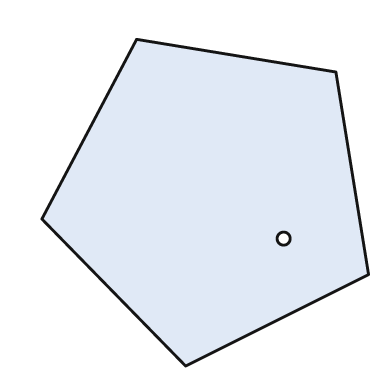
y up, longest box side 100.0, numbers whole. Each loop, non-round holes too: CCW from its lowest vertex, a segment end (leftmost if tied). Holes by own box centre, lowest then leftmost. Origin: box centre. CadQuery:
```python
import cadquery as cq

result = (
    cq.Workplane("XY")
    .moveTo(-6.0, -50.0)
    .lineTo(50.0, -22.0)
    .lineTo(40.0, 40.0)
    .lineTo(-21.0, 50.0)
    .lineTo(-50.0, -5.0)
    .close()
    .moveTo(24.0, -11.0)
    .circle(2.0)
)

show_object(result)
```